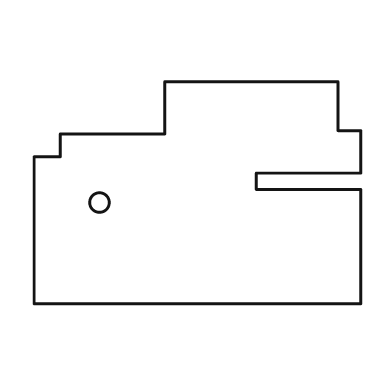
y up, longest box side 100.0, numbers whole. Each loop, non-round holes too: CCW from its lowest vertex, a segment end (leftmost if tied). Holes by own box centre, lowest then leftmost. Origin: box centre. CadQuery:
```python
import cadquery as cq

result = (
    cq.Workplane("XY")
    .moveTo(-50.0, -34.0)
    .lineTo(50.0, -34.0)
    .lineTo(50.0, 1.0)
    .lineTo(18.0, 1.0)
    .lineTo(18.0, 6.0)
    .lineTo(50.0, 6.0)
    .lineTo(50.0, 19.0)
    .lineTo(43.0, 19.0)
    .lineTo(43.0, 34.0)
    .lineTo(-10.0, 34.0)
    .lineTo(-10.0, 18.0)
    .lineTo(-42.0, 18.0)
    .lineTo(-42.0, 11.0)
    .lineTo(-50.0, 11.0)
    .close()
    .moveTo(-30.0, -3.0)
    .circle(3.0)
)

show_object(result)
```